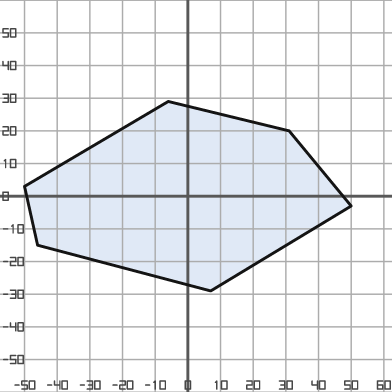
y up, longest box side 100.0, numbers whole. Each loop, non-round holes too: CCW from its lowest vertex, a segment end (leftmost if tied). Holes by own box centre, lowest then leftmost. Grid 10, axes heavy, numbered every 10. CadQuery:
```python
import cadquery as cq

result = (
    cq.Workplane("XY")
    .moveTo(7.0, -29.0)
    .lineTo(50.0, -3.0)
    .lineTo(31.0, 20.0)
    .lineTo(-6.0, 29.0)
    .lineTo(-50.0, 3.0)
    .lineTo(-46.0, -15.0)
    .close()
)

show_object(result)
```